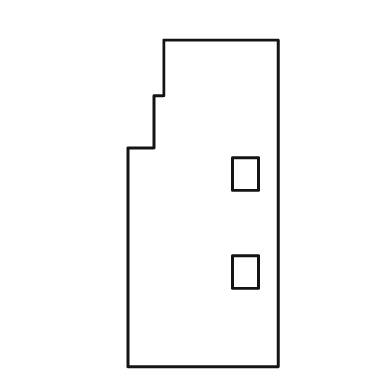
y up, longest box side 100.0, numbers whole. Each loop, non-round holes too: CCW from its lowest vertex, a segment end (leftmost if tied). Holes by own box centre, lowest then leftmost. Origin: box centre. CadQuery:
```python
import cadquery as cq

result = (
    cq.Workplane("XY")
    .moveTo(-23.0, -50.0)
    .lineTo(23.0, -50.0)
    .lineTo(23.0, 50.0)
    .lineTo(-12.0, 50.0)
    .lineTo(-12.0, 33.0)
    .lineTo(-15.0, 33.0)
    .lineTo(-15.0, 17.0)
    .lineTo(-23.0, 17.0)
    .close()
    .moveTo(9.0, -26.0)
    .lineTo(17.0, -26.0)
    .lineTo(17.0, -16.0)
    .lineTo(9.0, -16.0)
    .close()
    .moveTo(9.0, 4.0)
    .lineTo(17.0, 4.0)
    .lineTo(17.0, 14.0)
    .lineTo(9.0, 14.0)
    .close()
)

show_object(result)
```